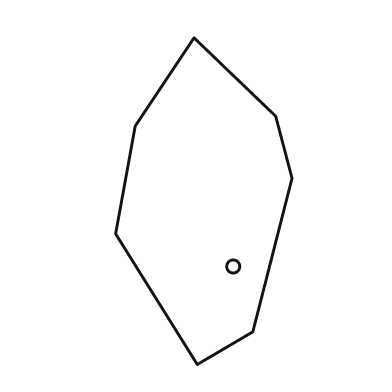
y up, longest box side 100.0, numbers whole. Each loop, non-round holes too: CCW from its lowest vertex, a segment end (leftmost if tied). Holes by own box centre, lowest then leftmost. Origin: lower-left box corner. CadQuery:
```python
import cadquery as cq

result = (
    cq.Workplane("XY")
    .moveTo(25.0, 0.0)
    .lineTo(42.0, 10.0)
    .lineTo(54.0, 57.0)
    .lineTo(49.0, 76.0)
    .lineTo(24.0, 100.0)
    .lineTo(6.0, 73.0)
    .lineTo(0.0, 40.0)
    .close()
    .moveTo(36.0, 30.0)
    .circle(2.0)
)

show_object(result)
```